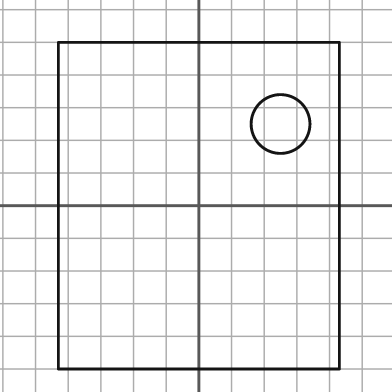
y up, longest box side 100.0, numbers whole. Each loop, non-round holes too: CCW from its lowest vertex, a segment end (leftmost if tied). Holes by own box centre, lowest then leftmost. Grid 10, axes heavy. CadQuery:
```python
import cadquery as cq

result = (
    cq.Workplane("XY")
    .moveTo(-43.0, -50.0)
    .lineTo(43.0, -50.0)
    .lineTo(43.0, 50.0)
    .lineTo(-43.0, 50.0)
    .close()
    .moveTo(25.0, 25.0)
    .circle(9.0)
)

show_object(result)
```